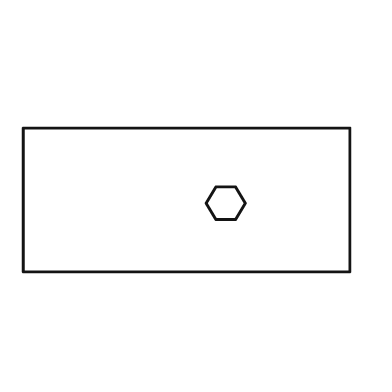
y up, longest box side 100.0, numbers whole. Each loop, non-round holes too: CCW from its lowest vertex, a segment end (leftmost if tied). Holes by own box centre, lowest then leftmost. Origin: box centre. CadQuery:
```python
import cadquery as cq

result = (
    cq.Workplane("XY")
    .moveTo(-50.0, -22.0)
    .lineTo(50.0, -22.0)
    .lineTo(50.0, 22.0)
    .lineTo(-50.0, 22.0)
    .close()
    .moveTo(9.0, -6.0)
    .lineTo(15.0, -6.0)
    .lineTo(18.0, -1.0)
    .lineTo(15.0, 4.0)
    .lineTo(9.0, 4.0)
    .lineTo(6.0, -1.0)
    .close()
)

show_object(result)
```